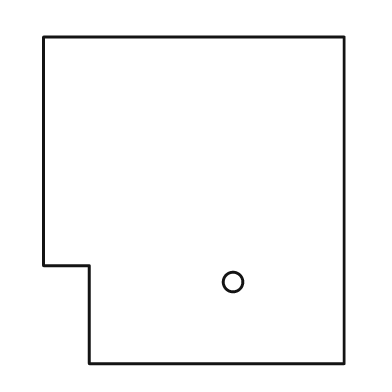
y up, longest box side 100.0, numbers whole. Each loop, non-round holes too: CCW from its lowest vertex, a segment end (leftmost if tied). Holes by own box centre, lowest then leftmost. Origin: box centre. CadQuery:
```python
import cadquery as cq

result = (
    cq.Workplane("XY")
    .moveTo(-32.0, -50.0)
    .lineTo(46.0, -50.0)
    .lineTo(46.0, 50.0)
    .lineTo(-46.0, 50.0)
    .lineTo(-46.0, -20.0)
    .lineTo(-32.0, -20.0)
    .close()
    .moveTo(12.0, -25.0)
    .circle(3.0)
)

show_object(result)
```